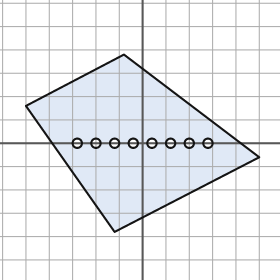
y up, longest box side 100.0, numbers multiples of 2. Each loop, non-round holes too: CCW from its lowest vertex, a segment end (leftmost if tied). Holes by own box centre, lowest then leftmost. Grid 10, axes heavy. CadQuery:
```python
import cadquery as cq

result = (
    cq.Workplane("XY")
    .moveTo(-12.0, -38.0)
    .lineTo(50.0, -6.0)
    .lineTo(-8.0, 38.0)
    .lineTo(-50.0, 16.0)
    .close()
    .moveTo(-28.0, 0.0)
    .circle(2.0)
    .moveTo(-20.0, 0.0)
    .circle(2.0)
    .moveTo(-12.0, 0.0)
    .circle(2.0)
    .moveTo(-4.0, 0.0)
    .circle(2.0)
    .moveTo(4.0, 0.0)
    .circle(2.0)
    .moveTo(12.0, 0.0)
    .circle(2.0)
    .moveTo(20.0, 0.0)
    .circle(2.0)
    .moveTo(28.0, 0.0)
    .circle(2.0)
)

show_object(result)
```